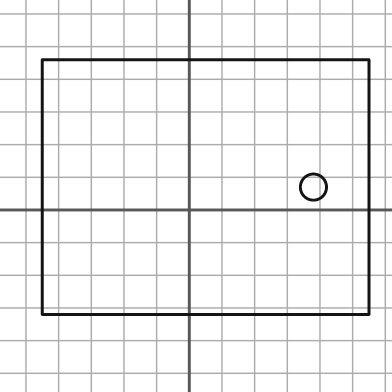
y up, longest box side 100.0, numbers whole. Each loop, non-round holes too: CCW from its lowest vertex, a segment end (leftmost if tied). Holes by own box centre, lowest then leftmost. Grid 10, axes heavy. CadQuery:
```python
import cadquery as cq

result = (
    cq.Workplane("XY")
    .moveTo(-45.0, -32.0)
    .lineTo(55.0, -32.0)
    .lineTo(55.0, 46.0)
    .lineTo(-45.0, 46.0)
    .close()
    .moveTo(38.0, 7.0)
    .circle(4.0)
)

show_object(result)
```